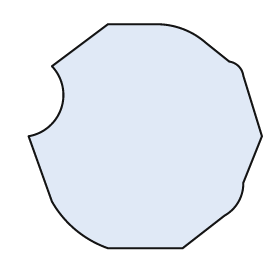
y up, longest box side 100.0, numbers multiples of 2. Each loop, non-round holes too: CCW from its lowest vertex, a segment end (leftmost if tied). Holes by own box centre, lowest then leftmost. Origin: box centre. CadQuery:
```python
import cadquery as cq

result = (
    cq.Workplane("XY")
    .moveTo(-16.0, -48.0)
    .lineTo(16.0, -48.0)
    .lineTo(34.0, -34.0)
    .threePointArc((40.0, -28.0), (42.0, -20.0))
    .lineTo(50.0, 0.0)
    .lineTo(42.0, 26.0)
    .threePointArc((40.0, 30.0), (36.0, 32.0))
    .lineTo(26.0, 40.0)
    .threePointArc((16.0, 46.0), (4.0, 48.0))
    .lineTo(-16.0, 48.0)
    .lineTo(-40.0, 30.0)
    .threePointArc((-36.0, 12.0), (-50.0, 0.0))
    .lineTo(-40.0, -28.0)
    .threePointArc((-30.0, -40.0), (-16.0, -48.0))
    .close()
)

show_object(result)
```